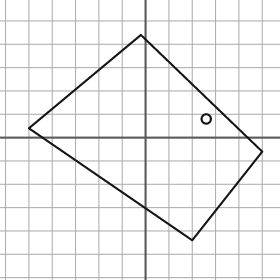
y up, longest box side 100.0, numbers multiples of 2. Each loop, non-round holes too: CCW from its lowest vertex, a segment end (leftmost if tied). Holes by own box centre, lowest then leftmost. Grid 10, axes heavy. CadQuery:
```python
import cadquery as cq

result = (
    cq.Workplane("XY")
    .moveTo(20.0, -44.0)
    .lineTo(50.0, -6.0)
    .lineTo(-2.0, 44.0)
    .lineTo(-50.0, 4.0)
    .close()
    .moveTo(26.0, 8.0)
    .circle(2.0)
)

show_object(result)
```